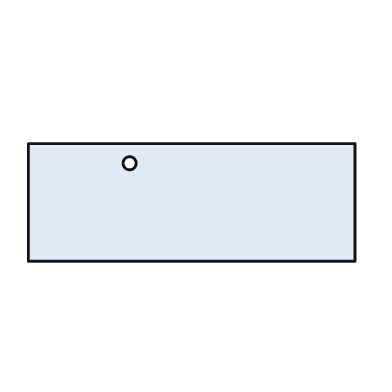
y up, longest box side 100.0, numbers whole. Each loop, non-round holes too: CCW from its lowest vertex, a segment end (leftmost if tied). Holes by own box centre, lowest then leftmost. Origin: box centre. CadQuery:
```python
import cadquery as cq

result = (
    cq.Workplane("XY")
    .moveTo(-50.0, -18.0)
    .lineTo(50.0, -18.0)
    .lineTo(50.0, 18.0)
    .lineTo(-50.0, 18.0)
    .close()
    .moveTo(-19.0, 12.0)
    .circle(2.0)
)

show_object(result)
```